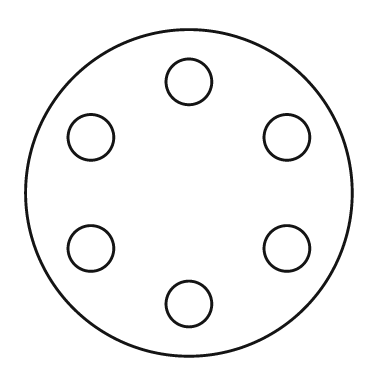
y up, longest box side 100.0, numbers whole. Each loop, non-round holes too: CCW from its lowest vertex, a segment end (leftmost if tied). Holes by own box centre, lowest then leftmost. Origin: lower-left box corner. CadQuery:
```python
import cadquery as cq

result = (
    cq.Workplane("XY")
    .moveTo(50.0, 50.0)
    .circle(50.0)
    .moveTo(50.0, 16.0)
    .circle(7.0)
    .moveTo(20.0, 33.0)
    .circle(7.0)
    .moveTo(80.0, 33.0)
    .circle(7.0)
    .moveTo(20.0, 67.0)
    .circle(7.0)
    .moveTo(80.0, 67.0)
    .circle(7.0)
    .moveTo(50.0, 84.0)
    .circle(7.0)
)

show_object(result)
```